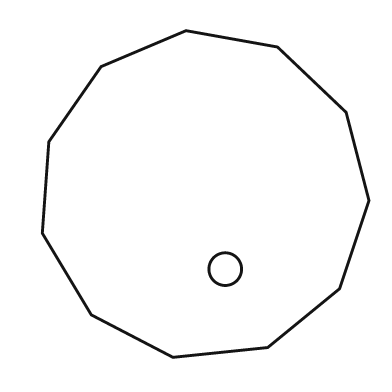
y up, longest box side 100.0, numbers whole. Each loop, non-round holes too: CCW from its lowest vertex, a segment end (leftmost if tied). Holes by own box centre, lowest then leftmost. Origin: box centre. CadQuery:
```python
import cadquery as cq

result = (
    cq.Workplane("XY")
    .moveTo(-10.0, -50.0)
    .lineTo(19.0, -47.0)
    .lineTo(41.0, -29.0)
    .lineTo(50.0, -2.0)
    .lineTo(43.0, 25.0)
    .lineTo(22.0, 45.0)
    .lineTo(-6.0, 50.0)
    .lineTo(-32.0, 39.0)
    .lineTo(-48.0, 16.0)
    .lineTo(-50.0, -12.0)
    .lineTo(-35.0, -37.0)
    .close()
    .moveTo(6.0, -23.0)
    .circle(5.0)
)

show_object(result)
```